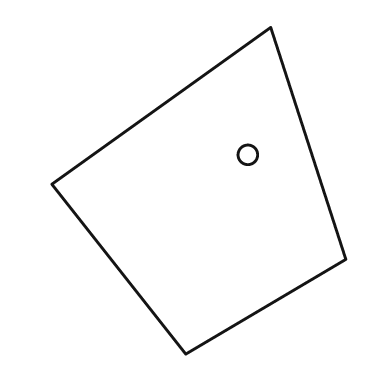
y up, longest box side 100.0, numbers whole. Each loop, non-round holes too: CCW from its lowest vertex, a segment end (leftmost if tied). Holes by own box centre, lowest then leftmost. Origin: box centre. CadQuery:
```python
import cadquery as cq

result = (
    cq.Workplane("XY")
    .moveTo(-4.0, -50.0)
    .lineTo(45.0, -21.0)
    .lineTo(22.0, 50.0)
    .lineTo(-45.0, 2.0)
    .close()
    .moveTo(15.0, 11.0)
    .circle(3.0)
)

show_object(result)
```